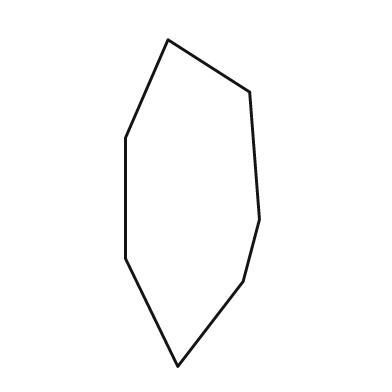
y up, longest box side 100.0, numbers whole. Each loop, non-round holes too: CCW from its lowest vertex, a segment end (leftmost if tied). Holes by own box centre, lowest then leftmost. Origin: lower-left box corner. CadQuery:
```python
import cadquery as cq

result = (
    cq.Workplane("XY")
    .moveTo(16.0, 0.0)
    .lineTo(36.0, 26.0)
    .lineTo(41.0, 45.0)
    .lineTo(38.0, 84.0)
    .lineTo(13.0, 100.0)
    .lineTo(0.0, 70.0)
    .lineTo(0.0, 33.0)
    .close()
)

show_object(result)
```